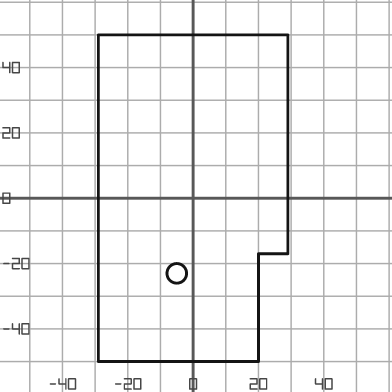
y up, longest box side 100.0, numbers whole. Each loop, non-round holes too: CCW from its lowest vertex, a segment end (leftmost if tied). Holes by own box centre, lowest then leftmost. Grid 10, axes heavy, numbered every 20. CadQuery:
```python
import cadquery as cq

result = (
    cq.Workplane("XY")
    .moveTo(-29.0, -50.0)
    .lineTo(20.0, -50.0)
    .lineTo(20.0, -17.0)
    .lineTo(29.0, -17.0)
    .lineTo(29.0, 50.0)
    .lineTo(-29.0, 50.0)
    .close()
    .moveTo(-5.0, -23.0)
    .circle(3.0)
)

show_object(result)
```